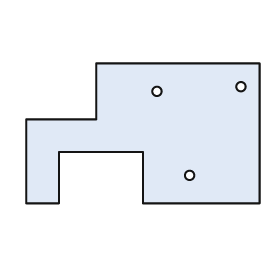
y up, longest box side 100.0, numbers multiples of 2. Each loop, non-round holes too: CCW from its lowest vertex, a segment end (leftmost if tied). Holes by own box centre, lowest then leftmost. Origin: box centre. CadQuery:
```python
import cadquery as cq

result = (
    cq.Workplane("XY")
    .moveTo(-50.0, -30.0)
    .lineTo(-36.0, -30.0)
    .lineTo(-36.0, -8.0)
    .lineTo(0.0, -8.0)
    .lineTo(0.0, -30.0)
    .lineTo(50.0, -30.0)
    .lineTo(50.0, 30.0)
    .lineTo(-20.0, 30.0)
    .lineTo(-20.0, 6.0)
    .lineTo(-50.0, 6.0)
    .close()
    .moveTo(20.0, -18.0)
    .circle(2.0)
    .moveTo(6.0, 18.0)
    .circle(2.0)
    .moveTo(42.0, 20.0)
    .circle(2.0)
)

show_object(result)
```